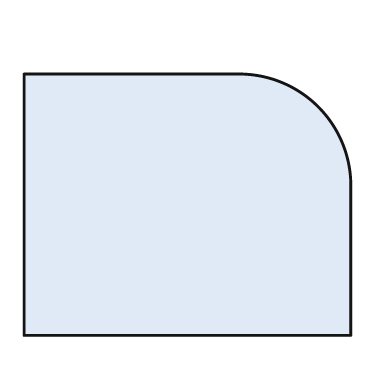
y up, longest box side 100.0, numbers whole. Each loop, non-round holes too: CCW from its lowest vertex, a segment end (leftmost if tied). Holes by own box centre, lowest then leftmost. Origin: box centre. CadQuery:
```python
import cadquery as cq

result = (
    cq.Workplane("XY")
    .moveTo(-50.0, -40.0)
    .lineTo(50.0, -40.0)
    .lineTo(50.0, 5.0)
    .threePointArc((40.0, 30.0), (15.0, 40.0))
    .lineTo(-50.0, 40.0)
    .close()
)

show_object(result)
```